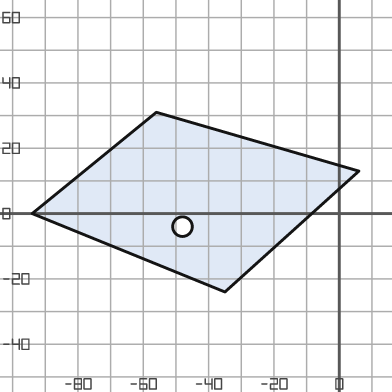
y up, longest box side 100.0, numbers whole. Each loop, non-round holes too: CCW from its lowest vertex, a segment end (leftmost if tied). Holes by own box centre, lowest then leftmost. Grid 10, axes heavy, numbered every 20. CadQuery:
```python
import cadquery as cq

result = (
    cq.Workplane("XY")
    .moveTo(-35.0, -24.0)
    .lineTo(6.0, 13.0)
    .lineTo(-56.0, 31.0)
    .lineTo(-94.0, 0.0)
    .close()
    .moveTo(-48.0, -4.0)
    .circle(3.0)
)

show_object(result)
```